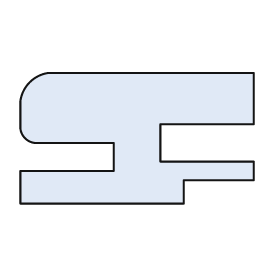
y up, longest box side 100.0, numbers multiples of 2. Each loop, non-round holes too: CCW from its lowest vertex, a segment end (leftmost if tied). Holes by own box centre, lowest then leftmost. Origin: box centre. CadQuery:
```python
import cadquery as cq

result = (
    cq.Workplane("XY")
    .moveTo(-50.0, -28.0)
    .lineTo(20.0, -28.0)
    .lineTo(20.0, -18.0)
    .lineTo(50.0, -18.0)
    .lineTo(50.0, -10.0)
    .lineTo(10.0, -10.0)
    .lineTo(10.0, 6.0)
    .lineTo(50.0, 6.0)
    .lineTo(50.0, 28.0)
    .lineTo(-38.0, 28.0)
    .threePointArc((-46.0, 24.0), (-50.0, 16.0))
    .lineTo(-50.0, 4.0)
    .threePointArc((-48.0, 0.0), (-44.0, -2.0))
    .lineTo(-10.0, -2.0)
    .lineTo(-10.0, -14.0)
    .lineTo(-50.0, -14.0)
    .close()
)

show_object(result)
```